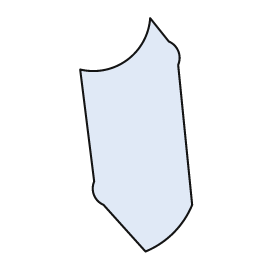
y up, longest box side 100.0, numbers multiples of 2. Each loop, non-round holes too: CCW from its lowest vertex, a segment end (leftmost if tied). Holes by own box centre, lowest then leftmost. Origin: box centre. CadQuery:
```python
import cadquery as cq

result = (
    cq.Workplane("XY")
    .moveTo(4.0, -50.0)
    .threePointArc((16.0, -42.0), (24.0, -30.0))
    .lineTo(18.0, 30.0)
    .threePointArc((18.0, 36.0), (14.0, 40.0))
    .lineTo(6.0, 50.0)
    .threePointArc((-4.0, 32.0), (-24.0, 28.0))
    .lineTo(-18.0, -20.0)
    .threePointArc((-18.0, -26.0), (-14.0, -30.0))
    .close()
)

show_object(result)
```